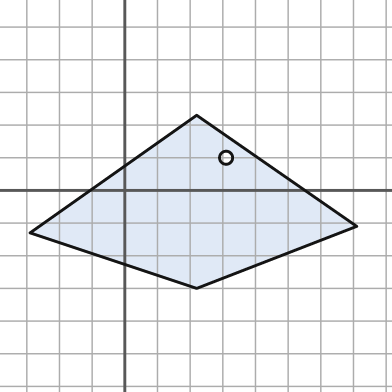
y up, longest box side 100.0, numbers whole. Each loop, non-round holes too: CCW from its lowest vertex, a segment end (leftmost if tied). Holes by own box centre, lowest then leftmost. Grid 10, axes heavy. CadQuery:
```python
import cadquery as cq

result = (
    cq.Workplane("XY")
    .moveTo(22.0, -30.0)
    .lineTo(71.0, -11.0)
    .lineTo(22.0, 23.0)
    .lineTo(-29.0, -13.0)
    .close()
    .moveTo(31.0, 10.0)
    .circle(2.0)
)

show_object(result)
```